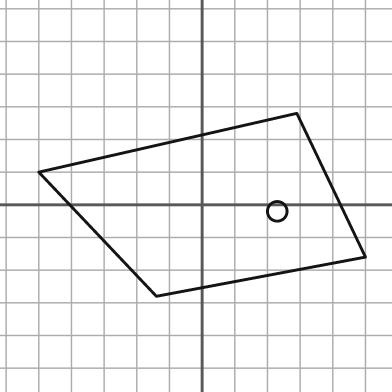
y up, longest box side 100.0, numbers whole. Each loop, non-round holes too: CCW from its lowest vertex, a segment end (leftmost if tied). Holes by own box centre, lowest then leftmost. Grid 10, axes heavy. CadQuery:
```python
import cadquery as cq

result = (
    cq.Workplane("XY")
    .moveTo(-14.0, -28.0)
    .lineTo(50.0, -16.0)
    .lineTo(29.0, 28.0)
    .lineTo(-50.0, 10.0)
    .close()
    .moveTo(23.0, -2.0)
    .circle(3.0)
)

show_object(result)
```